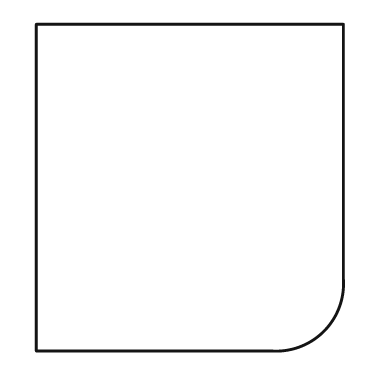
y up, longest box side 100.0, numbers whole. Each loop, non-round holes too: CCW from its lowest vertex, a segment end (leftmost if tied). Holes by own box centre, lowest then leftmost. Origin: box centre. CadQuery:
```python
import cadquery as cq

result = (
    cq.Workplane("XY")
    .moveTo(-47.0, -50.0)
    .lineTo(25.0, -50.0)
    .threePointArc((41.0, -44.0), (47.0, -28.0))
    .lineTo(47.0, 50.0)
    .lineTo(-47.0, 50.0)
    .close()
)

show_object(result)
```